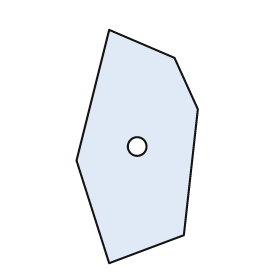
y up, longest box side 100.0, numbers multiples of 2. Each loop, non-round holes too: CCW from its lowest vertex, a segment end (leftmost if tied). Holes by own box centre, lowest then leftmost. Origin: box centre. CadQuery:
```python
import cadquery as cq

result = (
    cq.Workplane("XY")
    .moveTo(-12.0, -50.0)
    .lineTo(20.0, -38.0)
    .lineTo(26.0, 16.0)
    .lineTo(16.0, 38.0)
    .lineTo(-12.0, 50.0)
    .lineTo(-26.0, -6.0)
    .close()
    .moveTo(0.0, 0.0)
    .circle(4.0)
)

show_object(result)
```